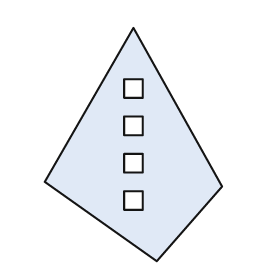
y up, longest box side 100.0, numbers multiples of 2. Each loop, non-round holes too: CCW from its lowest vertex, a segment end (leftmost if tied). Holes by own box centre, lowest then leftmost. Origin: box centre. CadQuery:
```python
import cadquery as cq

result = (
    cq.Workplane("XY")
    .moveTo(10.0, -50.0)
    .lineTo(38.0, -18.0)
    .lineTo(0.0, 50.0)
    .lineTo(-38.0, -16.0)
    .close()
    .moveTo(-4.0, -28.0)
    .lineTo(4.0, -28.0)
    .lineTo(4.0, -20.0)
    .lineTo(-4.0, -20.0)
    .close()
    .moveTo(-4.0, -12.0)
    .lineTo(4.0, -12.0)
    .lineTo(4.0, -4.0)
    .lineTo(-4.0, -4.0)
    .close()
    .moveTo(-4.0, 4.0)
    .lineTo(4.0, 4.0)
    .lineTo(4.0, 12.0)
    .lineTo(-4.0, 12.0)
    .close()
    .moveTo(-4.0, 20.0)
    .lineTo(4.0, 20.0)
    .lineTo(4.0, 28.0)
    .lineTo(-4.0, 28.0)
    .close()
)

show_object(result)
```